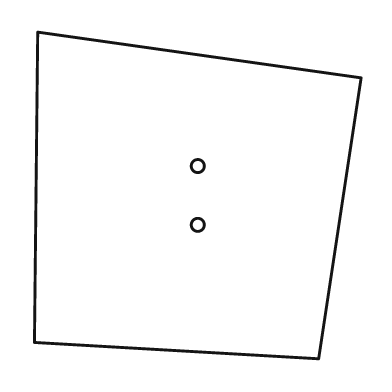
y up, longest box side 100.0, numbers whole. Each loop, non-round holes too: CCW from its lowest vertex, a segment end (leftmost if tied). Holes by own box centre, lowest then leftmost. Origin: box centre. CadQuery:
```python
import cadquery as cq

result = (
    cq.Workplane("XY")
    .moveTo(37.0, -50.0)
    .lineTo(50.0, 36.0)
    .lineTo(-49.0, 50.0)
    .lineTo(-50.0, -45.0)
    .close()
    .moveTo(0.0, -9.0)
    .circle(2.0)
    .moveTo(0.0, 9.0)
    .circle(2.0)
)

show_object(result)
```